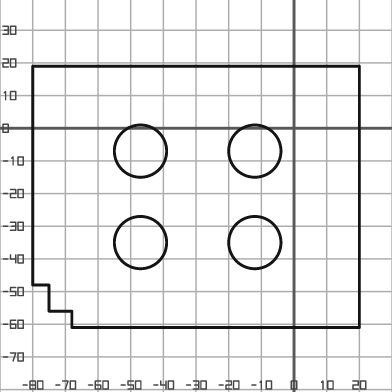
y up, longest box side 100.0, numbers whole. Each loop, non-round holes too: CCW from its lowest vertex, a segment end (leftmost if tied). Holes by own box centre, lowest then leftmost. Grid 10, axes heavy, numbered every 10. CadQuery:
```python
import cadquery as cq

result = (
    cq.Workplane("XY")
    .moveTo(-68.0, -61.0)
    .lineTo(20.0, -61.0)
    .lineTo(20.0, 19.0)
    .lineTo(-80.0, 19.0)
    .lineTo(-80.0, -48.0)
    .lineTo(-75.0, -48.0)
    .lineTo(-75.0, -56.0)
    .lineTo(-68.0, -56.0)
    .close()
    .moveTo(-47.0, -35.0)
    .circle(8.0)
    .moveTo(-12.0, -35.0)
    .circle(8.0)
    .moveTo(-47.0, -7.0)
    .circle(8.0)
    .moveTo(-12.0, -7.0)
    .circle(8.0)
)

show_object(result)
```